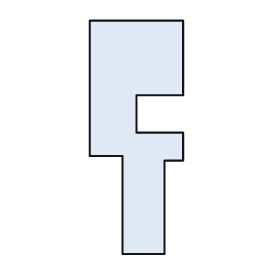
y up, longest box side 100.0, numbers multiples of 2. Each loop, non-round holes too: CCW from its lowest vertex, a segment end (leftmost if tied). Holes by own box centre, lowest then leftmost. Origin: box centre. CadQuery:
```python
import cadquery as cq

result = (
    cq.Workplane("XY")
    .moveTo(-6.0, -50.0)
    .lineTo(12.0, -50.0)
    .lineTo(12.0, -10.0)
    .lineTo(20.0, -10.0)
    .lineTo(20.0, 2.0)
    .lineTo(0.0, 2.0)
    .lineTo(0.0, 18.0)
    .lineTo(20.0, 18.0)
    .lineTo(20.0, 50.0)
    .lineTo(-20.0, 50.0)
    .lineTo(-20.0, -8.0)
    .lineTo(-6.0, -8.0)
    .close()
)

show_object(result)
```